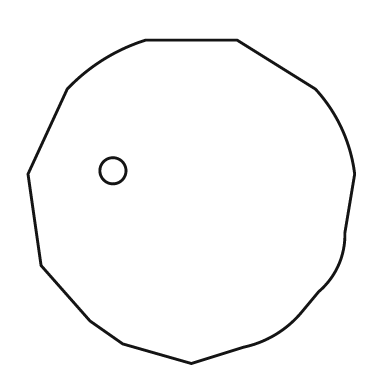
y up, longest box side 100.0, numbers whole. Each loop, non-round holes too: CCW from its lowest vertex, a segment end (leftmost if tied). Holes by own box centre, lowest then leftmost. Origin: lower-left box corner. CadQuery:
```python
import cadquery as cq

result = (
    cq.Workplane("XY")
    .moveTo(50.0, 0.0)
    .lineTo(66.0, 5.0)
    .threePointArc((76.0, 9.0), (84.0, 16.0))
    .lineTo(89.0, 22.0)
    .threePointArc((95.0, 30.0), (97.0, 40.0))
    .lineTo(100.0, 58.0)
    .threePointArc((96.0, 72.0), (88.0, 84.0))
    .lineTo(64.0, 99.0)
    .lineTo(36.0, 99.0)
    .threePointArc((23.0, 93.0), (12.0, 84.0))
    .lineTo(0.0, 58.0)
    .lineTo(4.0, 30.0)
    .lineTo(19.0, 13.0)
    .lineTo(29.0, 6.0)
    .close()
    .moveTo(26.0, 59.0)
    .circle(4.0)
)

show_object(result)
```